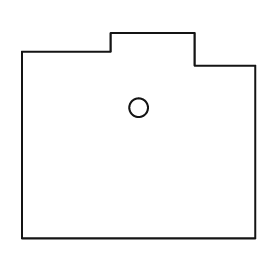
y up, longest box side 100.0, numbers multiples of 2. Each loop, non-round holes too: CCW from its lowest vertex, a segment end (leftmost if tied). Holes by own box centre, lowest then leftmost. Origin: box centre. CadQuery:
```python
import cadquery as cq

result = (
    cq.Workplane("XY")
    .moveTo(-50.0, -44.0)
    .lineTo(50.0, -44.0)
    .lineTo(50.0, 30.0)
    .lineTo(24.0, 30.0)
    .lineTo(24.0, 44.0)
    .lineTo(-12.0, 44.0)
    .lineTo(-12.0, 36.0)
    .lineTo(-50.0, 36.0)
    .close()
    .moveTo(0.0, 12.0)
    .circle(4.0)
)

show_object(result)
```